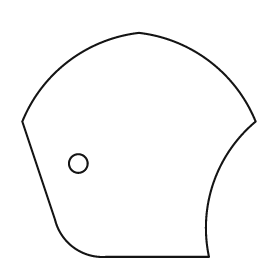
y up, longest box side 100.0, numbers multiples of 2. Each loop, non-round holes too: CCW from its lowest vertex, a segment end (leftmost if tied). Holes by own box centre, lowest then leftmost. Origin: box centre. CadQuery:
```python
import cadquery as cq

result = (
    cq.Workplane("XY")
    .moveTo(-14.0, -48.0)
    .lineTo(30.0, -48.0)
    .threePointArc((32.0, -16.0), (50.0, 10.0))
    .threePointArc((30.0, 36.0), (0.0, 48.0))
    .threePointArc((-30.0, 36.0), (-50.0, 10.0))
    .lineTo(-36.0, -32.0)
    .threePointArc((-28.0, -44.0), (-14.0, -48.0))
    .close()
    .moveTo(-26.0, -8.0)
    .circle(4.0)
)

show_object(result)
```